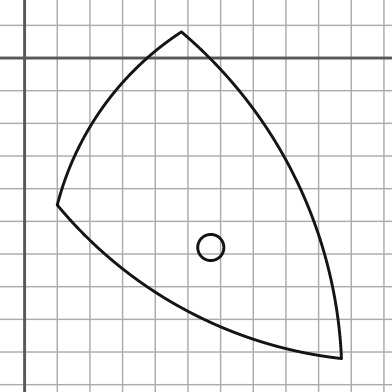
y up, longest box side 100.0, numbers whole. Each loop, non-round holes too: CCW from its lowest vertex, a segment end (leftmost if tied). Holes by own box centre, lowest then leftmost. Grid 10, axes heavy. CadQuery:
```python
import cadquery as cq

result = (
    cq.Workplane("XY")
    .moveTo(97.0, -92.0)
    .threePointArc((83.0, -37.0), (48.0, 8.0))
    .threePointArc((24.0, -15.0), (10.0, -45.0))
    .threePointArc((49.0, -77.0), (97.0, -92.0))
    .close()
    .moveTo(57.0, -58.0)
    .circle(4.0)
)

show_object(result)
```